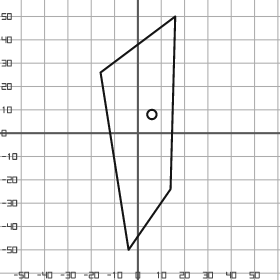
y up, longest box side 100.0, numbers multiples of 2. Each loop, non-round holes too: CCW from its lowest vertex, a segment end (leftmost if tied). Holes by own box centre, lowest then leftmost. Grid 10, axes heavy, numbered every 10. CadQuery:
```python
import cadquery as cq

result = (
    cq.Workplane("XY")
    .moveTo(-4.0, -50.0)
    .lineTo(14.0, -24.0)
    .lineTo(16.0, 50.0)
    .lineTo(-16.0, 26.0)
    .close()
    .moveTo(6.0, 8.0)
    .circle(2.0)
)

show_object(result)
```